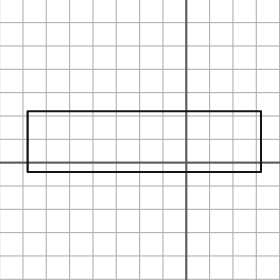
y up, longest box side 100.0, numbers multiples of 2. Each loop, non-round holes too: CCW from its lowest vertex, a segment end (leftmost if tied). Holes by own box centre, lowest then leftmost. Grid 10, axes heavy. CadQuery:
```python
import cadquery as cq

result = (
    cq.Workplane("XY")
    .moveTo(-68.0, -4.0)
    .lineTo(32.0, -4.0)
    .lineTo(32.0, 22.0)
    .lineTo(-68.0, 22.0)
    .close()
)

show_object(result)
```